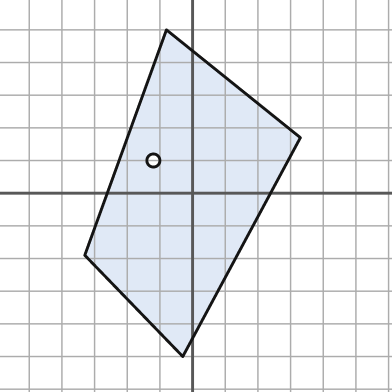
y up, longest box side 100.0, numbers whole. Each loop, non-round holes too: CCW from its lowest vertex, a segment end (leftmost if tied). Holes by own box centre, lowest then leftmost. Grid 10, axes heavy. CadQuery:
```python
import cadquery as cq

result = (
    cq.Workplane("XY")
    .moveTo(-3.0, -50.0)
    .lineTo(33.0, 17.0)
    .lineTo(-8.0, 50.0)
    .lineTo(-33.0, -19.0)
    .close()
    .moveTo(-12.0, 10.0)
    .circle(2.0)
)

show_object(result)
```